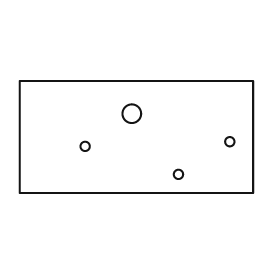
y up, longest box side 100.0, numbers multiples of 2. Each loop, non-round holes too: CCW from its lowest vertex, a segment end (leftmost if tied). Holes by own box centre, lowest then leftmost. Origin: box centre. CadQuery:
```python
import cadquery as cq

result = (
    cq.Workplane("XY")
    .moveTo(-50.0, -24.0)
    .lineTo(50.0, -24.0)
    .lineTo(50.0, 24.0)
    .lineTo(-50.0, 24.0)
    .close()
    .moveTo(18.0, -16.0)
    .circle(2.0)
    .moveTo(-22.0, -4.0)
    .circle(2.0)
    .moveTo(40.0, -2.0)
    .circle(2.0)
    .moveTo(-2.0, 10.0)
    .circle(4.0)
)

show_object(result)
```